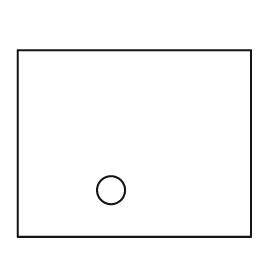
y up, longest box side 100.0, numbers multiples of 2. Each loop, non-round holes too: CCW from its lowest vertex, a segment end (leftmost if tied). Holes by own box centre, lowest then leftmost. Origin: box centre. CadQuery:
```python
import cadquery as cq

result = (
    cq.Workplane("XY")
    .moveTo(-50.0, -40.0)
    .lineTo(50.0, -40.0)
    .lineTo(50.0, 40.0)
    .lineTo(-50.0, 40.0)
    .close()
    .moveTo(-10.0, -20.0)
    .circle(6.0)
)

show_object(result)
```